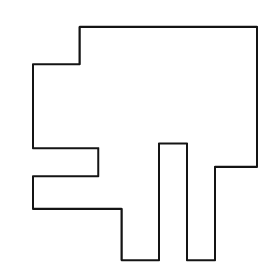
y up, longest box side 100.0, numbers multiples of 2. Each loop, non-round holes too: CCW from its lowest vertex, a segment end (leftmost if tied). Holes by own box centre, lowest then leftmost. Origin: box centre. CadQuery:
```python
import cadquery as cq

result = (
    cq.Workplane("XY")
    .moveTo(-10.0, -50.0)
    .lineTo(6.0, -50.0)
    .lineTo(6.0, 0.0)
    .lineTo(18.0, 0.0)
    .lineTo(18.0, -50.0)
    .lineTo(30.0, -50.0)
    .lineTo(30.0, -10.0)
    .lineTo(48.0, -10.0)
    .lineTo(48.0, 50.0)
    .lineTo(-28.0, 50.0)
    .lineTo(-28.0, 34.0)
    .lineTo(-48.0, 34.0)
    .lineTo(-48.0, -2.0)
    .lineTo(-20.0, -2.0)
    .lineTo(-20.0, -14.0)
    .lineTo(-48.0, -14.0)
    .lineTo(-48.0, -28.0)
    .lineTo(-10.0, -28.0)
    .close()
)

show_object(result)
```